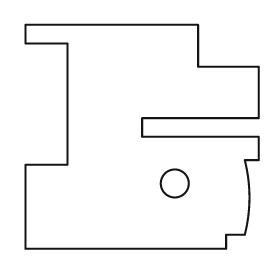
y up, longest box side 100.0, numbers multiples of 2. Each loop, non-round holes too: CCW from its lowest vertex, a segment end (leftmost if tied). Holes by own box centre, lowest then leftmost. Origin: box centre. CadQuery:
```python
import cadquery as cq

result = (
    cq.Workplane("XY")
    .moveTo(-50.0, -48.0)
    .lineTo(36.0, -48.0)
    .lineTo(36.0, -42.0)
    .lineTo(44.0, -42.0)
    .threePointArc((46.0, -26.0), (44.0, -10.0))
    .lineTo(50.0, -10.0)
    .lineTo(50.0, 0.0)
    .lineTo(0.0, 0.0)
    .lineTo(0.0, 8.0)
    .lineTo(50.0, 8.0)
    .lineTo(50.0, 30.0)
    .lineTo(24.0, 30.0)
    .lineTo(24.0, 48.0)
    .lineTo(-50.0, 48.0)
    .lineTo(-50.0, 40.0)
    .lineTo(-32.0, 40.0)
    .lineTo(-32.0, -12.0)
    .lineTo(-50.0, -12.0)
    .close()
    .moveTo(14.0, -20.0)
    .circle(6.0)
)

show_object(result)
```